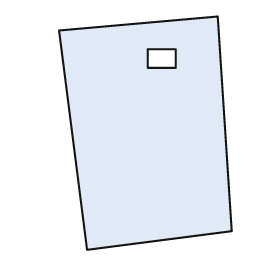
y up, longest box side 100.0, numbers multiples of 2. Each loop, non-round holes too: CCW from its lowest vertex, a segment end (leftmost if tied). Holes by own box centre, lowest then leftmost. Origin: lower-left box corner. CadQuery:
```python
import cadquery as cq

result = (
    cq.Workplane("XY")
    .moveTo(12.0, 0.0)
    .lineTo(74.0, 8.0)
    .lineTo(68.0, 100.0)
    .lineTo(0.0, 94.0)
    .close()
    .moveTo(38.0, 78.0)
    .lineTo(50.0, 78.0)
    .lineTo(50.0, 86.0)
    .lineTo(38.0, 86.0)
    .close()
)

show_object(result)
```